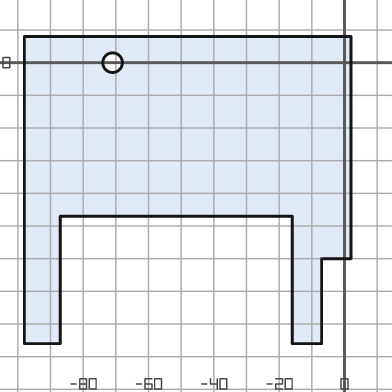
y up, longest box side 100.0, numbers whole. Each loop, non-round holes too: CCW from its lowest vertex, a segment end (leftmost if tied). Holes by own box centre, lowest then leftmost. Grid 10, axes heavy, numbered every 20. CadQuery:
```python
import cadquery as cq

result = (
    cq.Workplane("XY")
    .moveTo(-98.0, -86.0)
    .lineTo(-87.0, -86.0)
    .lineTo(-87.0, -47.0)
    .lineTo(-16.0, -47.0)
    .lineTo(-16.0, -86.0)
    .lineTo(-7.0, -86.0)
    .lineTo(-7.0, -60.0)
    .lineTo(2.0, -60.0)
    .lineTo(2.0, 8.0)
    .lineTo(-98.0, 8.0)
    .close()
    .moveTo(-71.0, 0.0)
    .circle(3.0)
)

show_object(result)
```